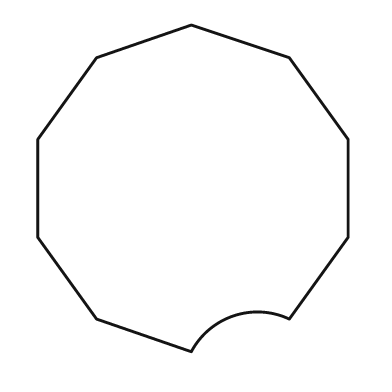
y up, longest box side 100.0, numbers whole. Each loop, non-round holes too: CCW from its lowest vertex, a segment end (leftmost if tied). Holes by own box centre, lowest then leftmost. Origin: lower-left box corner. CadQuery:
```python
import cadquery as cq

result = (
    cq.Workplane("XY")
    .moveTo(47.0, 0.0)
    .threePointArc((60.0, 11.0), (77.0, 10.0))
    .lineTo(95.0, 35.0)
    .lineTo(95.0, 65.0)
    .lineTo(77.0, 90.0)
    .lineTo(47.0, 100.0)
    .lineTo(18.0, 90.0)
    .lineTo(0.0, 65.0)
    .lineTo(0.0, 35.0)
    .lineTo(18.0, 10.0)
    .close()
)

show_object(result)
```